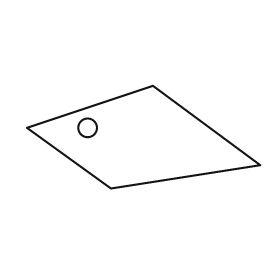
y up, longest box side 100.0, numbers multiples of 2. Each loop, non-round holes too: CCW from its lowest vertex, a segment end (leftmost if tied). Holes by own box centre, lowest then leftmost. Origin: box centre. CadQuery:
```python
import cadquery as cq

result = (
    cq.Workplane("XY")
    .moveTo(-14.0, -22.0)
    .lineTo(50.0, -12.0)
    .lineTo(4.0, 22.0)
    .lineTo(-50.0, 4.0)
    .close()
    .moveTo(-24.0, 4.0)
    .circle(4.0)
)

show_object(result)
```